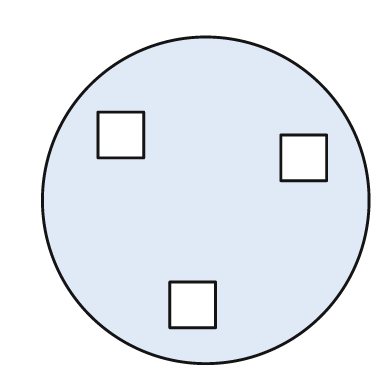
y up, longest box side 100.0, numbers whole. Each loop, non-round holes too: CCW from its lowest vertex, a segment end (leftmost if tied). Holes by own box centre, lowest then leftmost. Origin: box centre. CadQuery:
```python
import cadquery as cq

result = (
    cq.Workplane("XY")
    .moveTo(0.0, 0.0)
    .circle(50.0)
    .moveTo(-11.0, -39.0)
    .lineTo(3.0, -39.0)
    .lineTo(3.0, -25.0)
    .lineTo(-11.0, -25.0)
    .close()
    .moveTo(23.0, 6.0)
    .lineTo(37.0, 6.0)
    .lineTo(37.0, 20.0)
    .lineTo(23.0, 20.0)
    .close()
    .moveTo(-33.0, 13.0)
    .lineTo(-19.0, 13.0)
    .lineTo(-19.0, 27.0)
    .lineTo(-33.0, 27.0)
    .close()
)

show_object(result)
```